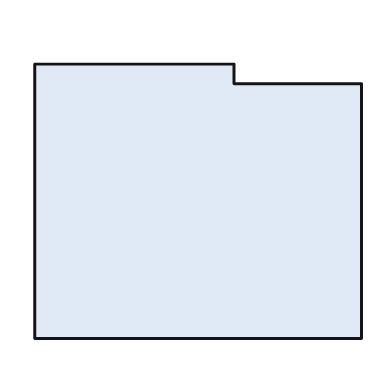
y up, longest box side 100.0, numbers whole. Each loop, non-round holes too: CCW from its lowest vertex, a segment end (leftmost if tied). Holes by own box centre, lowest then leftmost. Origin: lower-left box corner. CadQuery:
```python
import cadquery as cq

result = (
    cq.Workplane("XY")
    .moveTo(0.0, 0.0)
    .lineTo(100.0, 0.0)
    .lineTo(100.0, 78.0)
    .lineTo(61.0, 78.0)
    .lineTo(61.0, 84.0)
    .lineTo(0.0, 84.0)
    .close()
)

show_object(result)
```